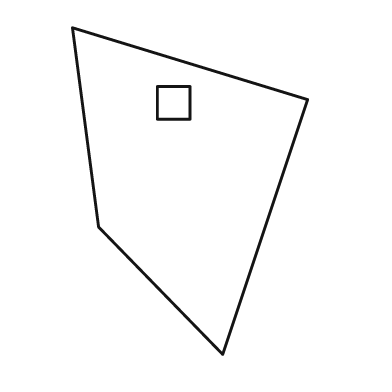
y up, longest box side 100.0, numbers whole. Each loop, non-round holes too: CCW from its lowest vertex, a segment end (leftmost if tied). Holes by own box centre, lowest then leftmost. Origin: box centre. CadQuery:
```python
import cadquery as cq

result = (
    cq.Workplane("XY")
    .moveTo(10.0, -50.0)
    .lineTo(36.0, 28.0)
    .lineTo(-36.0, 50.0)
    .lineTo(-28.0, -11.0)
    .close()
    .moveTo(-10.0, 22.0)
    .lineTo(0.0, 22.0)
    .lineTo(0.0, 32.0)
    .lineTo(-10.0, 32.0)
    .close()
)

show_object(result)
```